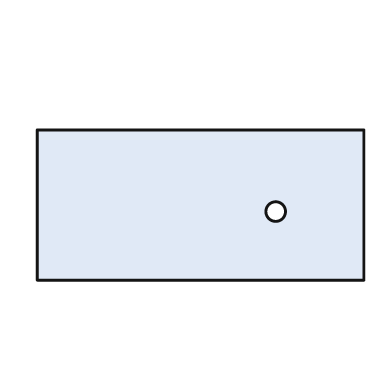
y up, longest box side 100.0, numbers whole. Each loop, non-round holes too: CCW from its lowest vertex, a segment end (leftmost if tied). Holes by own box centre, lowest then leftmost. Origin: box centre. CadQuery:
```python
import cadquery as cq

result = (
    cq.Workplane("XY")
    .moveTo(-50.0, -23.0)
    .lineTo(50.0, -23.0)
    .lineTo(50.0, 23.0)
    .lineTo(-50.0, 23.0)
    .close()
    .moveTo(23.0, -2.0)
    .circle(3.0)
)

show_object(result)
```